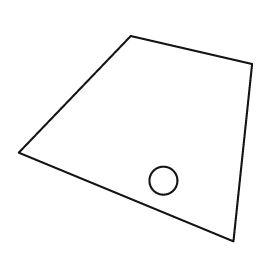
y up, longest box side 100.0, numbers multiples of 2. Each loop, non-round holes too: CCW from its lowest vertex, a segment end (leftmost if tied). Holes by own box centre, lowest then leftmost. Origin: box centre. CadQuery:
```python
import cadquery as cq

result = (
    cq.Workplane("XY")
    .moveTo(42.0, -44.0)
    .lineTo(50.0, 32.0)
    .lineTo(-2.0, 44.0)
    .lineTo(-50.0, -6.0)
    .close()
    .moveTo(12.0, -18.0)
    .circle(6.0)
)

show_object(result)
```